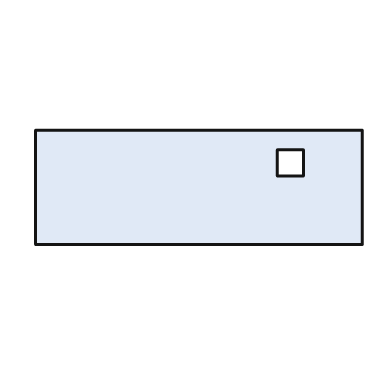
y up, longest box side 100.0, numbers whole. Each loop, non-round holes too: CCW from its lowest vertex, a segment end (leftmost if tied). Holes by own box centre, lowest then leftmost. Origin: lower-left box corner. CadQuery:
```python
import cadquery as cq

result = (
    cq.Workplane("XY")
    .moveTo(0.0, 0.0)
    .lineTo(100.0, 0.0)
    .lineTo(100.0, 35.0)
    .lineTo(0.0, 35.0)
    .close()
    .moveTo(74.0, 21.0)
    .lineTo(82.0, 21.0)
    .lineTo(82.0, 29.0)
    .lineTo(74.0, 29.0)
    .close()
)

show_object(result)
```